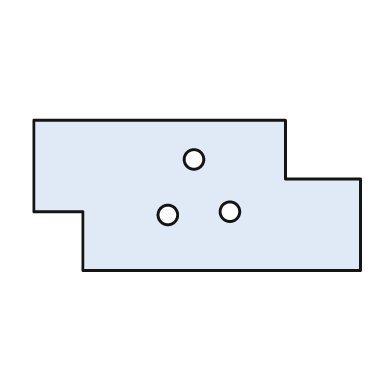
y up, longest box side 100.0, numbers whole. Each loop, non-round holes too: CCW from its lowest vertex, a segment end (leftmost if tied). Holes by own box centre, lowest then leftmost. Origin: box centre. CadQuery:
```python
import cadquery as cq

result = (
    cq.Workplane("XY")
    .moveTo(-35.0, -23.0)
    .lineTo(50.0, -23.0)
    .lineTo(50.0, 5.0)
    .lineTo(27.0, 5.0)
    .lineTo(27.0, 23.0)
    .lineTo(-50.0, 23.0)
    .lineTo(-50.0, -5.0)
    .lineTo(-35.0, -5.0)
    .close()
    .moveTo(-9.0, -6.0)
    .circle(3.0)
    .moveTo(10.0, -5.0)
    .circle(3.0)
    .moveTo(-1.0, 11.0)
    .circle(3.0)
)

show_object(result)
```